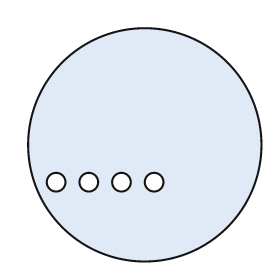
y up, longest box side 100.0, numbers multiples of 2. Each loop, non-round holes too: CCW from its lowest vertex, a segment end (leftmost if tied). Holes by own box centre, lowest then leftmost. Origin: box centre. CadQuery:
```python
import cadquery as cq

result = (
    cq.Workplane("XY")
    .moveTo(0.0, 0.0)
    .circle(50.0)
    .moveTo(-38.0, -16.0)
    .circle(4.0)
    .moveTo(-24.0, -16.0)
    .circle(4.0)
    .moveTo(-10.0, -16.0)
    .circle(4.0)
    .moveTo(4.0, -16.0)
    .circle(4.0)
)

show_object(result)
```